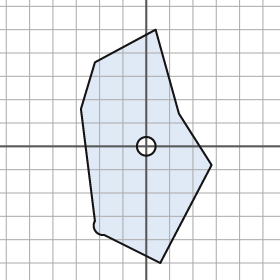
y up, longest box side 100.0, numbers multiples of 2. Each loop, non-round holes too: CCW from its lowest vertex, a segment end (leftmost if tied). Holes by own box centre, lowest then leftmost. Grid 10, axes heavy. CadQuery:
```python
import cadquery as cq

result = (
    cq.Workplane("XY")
    .moveTo(6.0, -50.0)
    .lineTo(28.0, -8.0)
    .lineTo(14.0, 14.0)
    .lineTo(4.0, 50.0)
    .lineTo(-22.0, 36.0)
    .lineTo(-28.0, 16.0)
    .lineTo(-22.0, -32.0)
    .threePointArc((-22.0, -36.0), (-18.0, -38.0))
    .close()
    .moveTo(0.0, 0.0)
    .circle(4.0)
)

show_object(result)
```